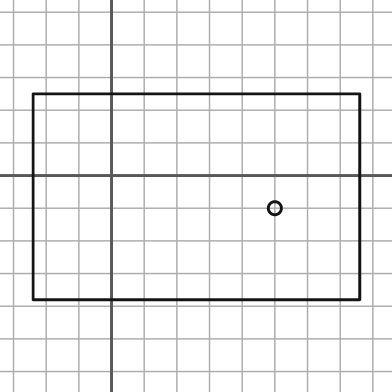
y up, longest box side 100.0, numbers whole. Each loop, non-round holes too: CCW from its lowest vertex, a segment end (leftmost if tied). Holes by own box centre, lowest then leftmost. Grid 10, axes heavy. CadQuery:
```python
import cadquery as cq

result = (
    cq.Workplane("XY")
    .moveTo(-24.0, -38.0)
    .lineTo(76.0, -38.0)
    .lineTo(76.0, 25.0)
    .lineTo(-24.0, 25.0)
    .close()
    .moveTo(50.0, -10.0)
    .circle(2.0)
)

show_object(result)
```